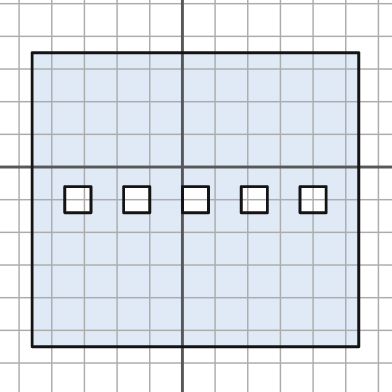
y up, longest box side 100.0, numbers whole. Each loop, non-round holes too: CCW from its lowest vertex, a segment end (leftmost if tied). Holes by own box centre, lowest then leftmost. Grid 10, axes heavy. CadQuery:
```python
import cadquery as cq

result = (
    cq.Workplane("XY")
    .moveTo(-46.0, -55.0)
    .lineTo(54.0, -55.0)
    .lineTo(54.0, 35.0)
    .lineTo(-46.0, 35.0)
    .close()
    .moveTo(-36.0, -14.0)
    .lineTo(-28.0, -14.0)
    .lineTo(-28.0, -6.0)
    .lineTo(-36.0, -6.0)
    .close()
    .moveTo(-18.0, -14.0)
    .lineTo(-10.0, -14.0)
    .lineTo(-10.0, -6.0)
    .lineTo(-18.0, -6.0)
    .close()
    .moveTo(0.0, -14.0)
    .lineTo(8.0, -14.0)
    .lineTo(8.0, -6.0)
    .lineTo(0.0, -6.0)
    .close()
    .moveTo(18.0, -14.0)
    .lineTo(26.0, -14.0)
    .lineTo(26.0, -6.0)
    .lineTo(18.0, -6.0)
    .close()
    .moveTo(36.0, -14.0)
    .lineTo(44.0, -14.0)
    .lineTo(44.0, -6.0)
    .lineTo(36.0, -6.0)
    .close()
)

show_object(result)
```